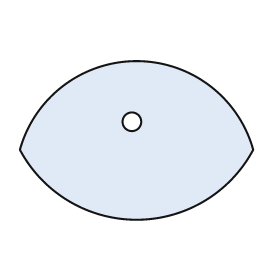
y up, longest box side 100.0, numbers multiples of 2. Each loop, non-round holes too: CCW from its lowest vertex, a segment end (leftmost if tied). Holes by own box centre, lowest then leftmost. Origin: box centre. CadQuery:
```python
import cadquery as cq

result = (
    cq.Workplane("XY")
    .moveTo(-50.0, -4.0)
    .threePointArc((0.0, -34.0), (50.0, -4.0))
    .threePointArc((0.0, 34.0), (-50.0, -4.0))
    .close()
    .moveTo(-2.0, 8.0)
    .circle(4.0)
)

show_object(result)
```